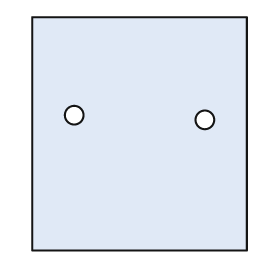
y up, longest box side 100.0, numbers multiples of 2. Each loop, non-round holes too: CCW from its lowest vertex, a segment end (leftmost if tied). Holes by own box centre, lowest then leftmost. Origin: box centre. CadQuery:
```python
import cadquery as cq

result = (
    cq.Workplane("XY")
    .moveTo(-46.0, -50.0)
    .lineTo(46.0, -50.0)
    .lineTo(46.0, 50.0)
    .lineTo(-46.0, 50.0)
    .close()
    .moveTo(28.0, 6.0)
    .circle(4.0)
    .moveTo(-28.0, 8.0)
    .circle(4.0)
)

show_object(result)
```